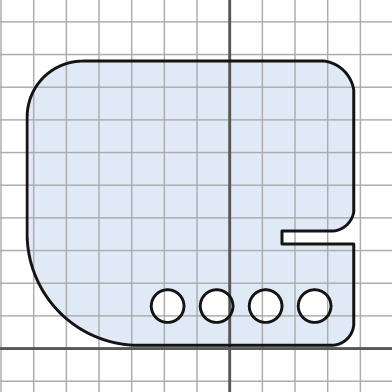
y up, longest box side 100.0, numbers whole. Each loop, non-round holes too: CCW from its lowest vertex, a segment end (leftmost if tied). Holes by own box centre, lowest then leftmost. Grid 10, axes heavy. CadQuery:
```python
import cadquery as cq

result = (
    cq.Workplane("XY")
    .moveTo(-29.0, 1.0)
    .lineTo(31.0, 1.0)
    .threePointArc((36.0, 3.0), (38.0, 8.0))
    .lineTo(38.0, 32.0)
    .lineTo(16.0, 32.0)
    .lineTo(16.0, 36.0)
    .lineTo(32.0, 36.0)
    .threePointArc((36.0, 38.0), (38.0, 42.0))
    .lineTo(38.0, 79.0)
    .threePointArc((35.0, 85.0), (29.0, 88.0))
    .lineTo(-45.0, 88.0)
    .threePointArc((-57.0, 83.0), (-62.0, 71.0))
    .lineTo(-62.0, 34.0)
    .threePointArc((-52.0, 11.0), (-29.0, 1.0))
    .close()
    .moveTo(-19.0, 13.0)
    .circle(5.0)
    .moveTo(-4.0, 13.0)
    .circle(5.0)
    .moveTo(11.0, 13.0)
    .circle(5.0)
    .moveTo(26.0, 13.0)
    .circle(5.0)
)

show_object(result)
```